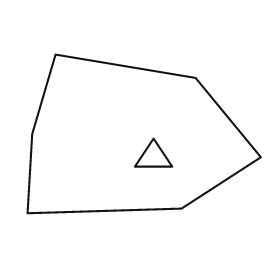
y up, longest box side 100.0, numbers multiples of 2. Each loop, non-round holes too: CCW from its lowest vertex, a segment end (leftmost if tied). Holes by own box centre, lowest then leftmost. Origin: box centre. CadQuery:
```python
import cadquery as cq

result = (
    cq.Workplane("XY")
    .moveTo(-50.0, -34.0)
    .lineTo(16.0, -32.0)
    .lineTo(50.0, -10.0)
    .lineTo(22.0, 24.0)
    .lineTo(-38.0, 34.0)
    .lineTo(-48.0, 0.0)
    .close()
    .moveTo(-4.0, -14.0)
    .lineTo(12.0, -14.0)
    .lineTo(4.0, -2.0)
    .close()
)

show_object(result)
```